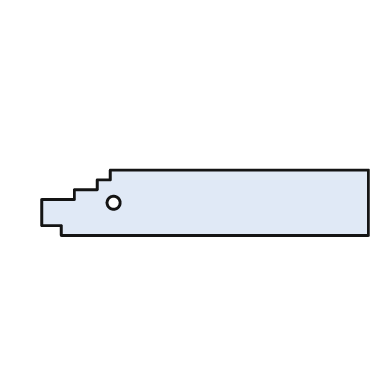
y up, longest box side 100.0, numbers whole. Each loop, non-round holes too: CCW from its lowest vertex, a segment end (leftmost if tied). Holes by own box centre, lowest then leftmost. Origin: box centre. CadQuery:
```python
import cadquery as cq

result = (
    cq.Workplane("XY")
    .moveTo(-44.0, -10.0)
    .lineTo(50.0, -10.0)
    .lineTo(50.0, 10.0)
    .lineTo(-29.0, 10.0)
    .lineTo(-29.0, 7.0)
    .lineTo(-33.0, 7.0)
    .lineTo(-33.0, 4.0)
    .lineTo(-40.0, 4.0)
    .lineTo(-40.0, 1.0)
    .lineTo(-50.0, 1.0)
    .lineTo(-50.0, -7.0)
    .lineTo(-44.0, -7.0)
    .close()
    .moveTo(-28.0, 0.0)
    .circle(2.0)
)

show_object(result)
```